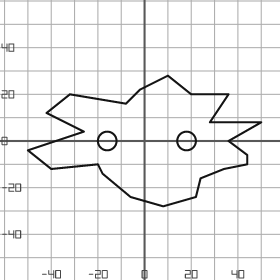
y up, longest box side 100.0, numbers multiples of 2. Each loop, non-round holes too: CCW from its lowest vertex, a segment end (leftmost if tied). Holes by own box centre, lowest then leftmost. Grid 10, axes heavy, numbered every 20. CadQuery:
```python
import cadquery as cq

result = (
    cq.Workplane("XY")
    .moveTo(8.0, -28.0)
    .lineTo(22.0, -24.0)
    .lineTo(24.0, -16.0)
    .lineTo(34.0, -12.0)
    .lineTo(44.0, -10.0)
    .lineTo(44.0, -6.0)
    .lineTo(36.0, 0.0)
    .lineTo(50.0, 8.0)
    .lineTo(28.0, 8.0)
    .lineTo(36.0, 20.0)
    .lineTo(20.0, 20.0)
    .lineTo(10.0, 28.0)
    .lineTo(-2.0, 22.0)
    .lineTo(-8.0, 16.0)
    .lineTo(-32.0, 20.0)
    .lineTo(-42.0, 12.0)
    .lineTo(-26.0, 4.0)
    .lineTo(-50.0, -4.0)
    .lineTo(-40.0, -12.0)
    .lineTo(-20.0, -10.0)
    .lineTo(-18.0, -14.0)
    .lineTo(-6.0, -24.0)
    .close()
    .moveTo(-16.0, 0.0)
    .circle(4.0)
    .moveTo(18.0, 0.0)
    .circle(4.0)
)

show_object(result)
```